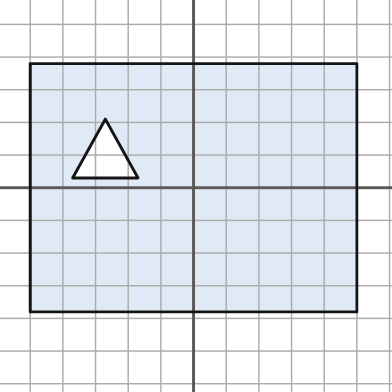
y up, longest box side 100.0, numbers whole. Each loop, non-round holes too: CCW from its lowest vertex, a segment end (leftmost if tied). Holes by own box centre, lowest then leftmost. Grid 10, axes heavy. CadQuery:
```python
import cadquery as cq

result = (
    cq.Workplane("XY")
    .moveTo(-50.0, -38.0)
    .lineTo(50.0, -38.0)
    .lineTo(50.0, 38.0)
    .lineTo(-50.0, 38.0)
    .close()
    .moveTo(-37.0, 3.0)
    .lineTo(-17.0, 3.0)
    .lineTo(-27.0, 21.0)
    .close()
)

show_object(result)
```